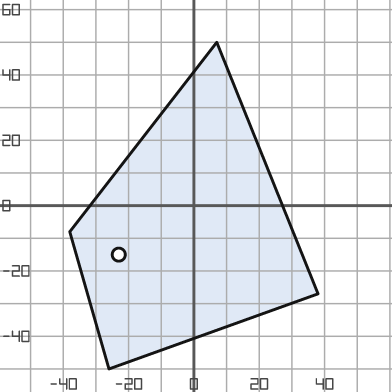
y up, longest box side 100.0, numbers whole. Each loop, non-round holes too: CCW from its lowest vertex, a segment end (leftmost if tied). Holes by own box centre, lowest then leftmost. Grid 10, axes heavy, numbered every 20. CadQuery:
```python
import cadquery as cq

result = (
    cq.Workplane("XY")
    .moveTo(-26.0, -50.0)
    .lineTo(38.0, -27.0)
    .lineTo(7.0, 50.0)
    .lineTo(-38.0, -8.0)
    .close()
    .moveTo(-23.0, -15.0)
    .circle(2.0)
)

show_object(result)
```